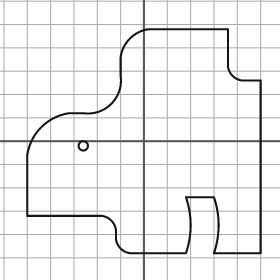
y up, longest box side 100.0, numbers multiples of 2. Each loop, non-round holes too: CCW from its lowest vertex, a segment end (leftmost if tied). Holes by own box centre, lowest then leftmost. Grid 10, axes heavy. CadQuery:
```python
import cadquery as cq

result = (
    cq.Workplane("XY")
    .moveTo(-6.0, -48.0)
    .lineTo(18.0, -48.0)
    .threePointArc((20.0, -36.0), (18.0, -24.0))
    .lineTo(30.0, -24.0)
    .threePointArc((32.0, -36.0), (30.0, -48.0))
    .lineTo(50.0, -48.0)
    .lineTo(50.0, 26.0)
    .lineTo(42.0, 26.0)
    .threePointArc((38.0, 28.0), (36.0, 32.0))
    .lineTo(36.0, 48.0)
    .lineTo(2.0, 48.0)
    .threePointArc((-6.0, 44.0), (-10.0, 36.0))
    .lineTo(-10.0, 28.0)
    .threePointArc((-14.0, 16.0), (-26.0, 12.0))
    .lineTo(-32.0, 12.0)
    .threePointArc((-44.0, 6.0), (-50.0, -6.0))
    .lineTo(-50.0, -32.0)
    .lineTo(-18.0, -32.0)
    .threePointArc((-14.0, -34.0), (-12.0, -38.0))
    .lineTo(-12.0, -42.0)
    .threePointArc((-10.0, -46.0), (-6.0, -48.0))
    .close()
    .moveTo(-26.0, -2.0)
    .circle(2.0)
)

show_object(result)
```